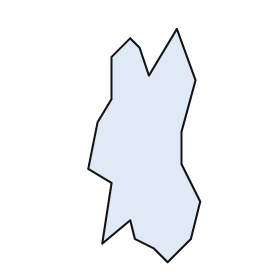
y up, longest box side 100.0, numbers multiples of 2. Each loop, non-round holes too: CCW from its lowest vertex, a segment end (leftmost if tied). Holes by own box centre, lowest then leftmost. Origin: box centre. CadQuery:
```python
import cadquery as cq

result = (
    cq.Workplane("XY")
    .moveTo(10.0, -50.0)
    .lineTo(20.0, -40.0)
    .lineTo(24.0, -24.0)
    .lineTo(16.0, -8.0)
    .lineTo(16.0, 6.0)
    .lineTo(22.0, 28.0)
    .lineTo(14.0, 50.0)
    .lineTo(2.0, 30.0)
    .lineTo(-2.0, 42.0)
    .lineTo(-6.0, 46.0)
    .lineTo(-14.0, 38.0)
    .lineTo(-14.0, 20.0)
    .lineTo(-20.0, 10.0)
    .lineTo(-24.0, -10.0)
    .lineTo(-14.0, -16.0)
    .lineTo(-18.0, -42.0)
    .lineTo(-6.0, -32.0)
    .lineTo(-4.0, -40.0)
    .lineTo(4.0, -44.0)
    .close()
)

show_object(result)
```